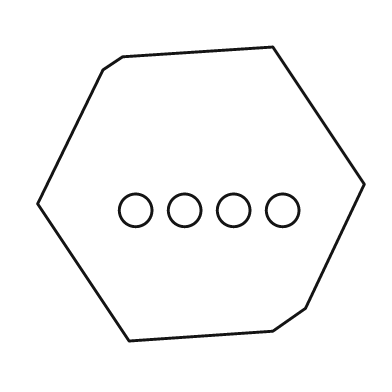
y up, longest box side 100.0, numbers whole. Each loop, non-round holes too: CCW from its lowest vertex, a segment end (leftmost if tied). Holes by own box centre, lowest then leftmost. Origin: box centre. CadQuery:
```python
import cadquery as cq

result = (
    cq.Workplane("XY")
    .moveTo(-22.0, -45.0)
    .lineTo(22.0, -42.0)
    .lineTo(32.0, -35.0)
    .lineTo(50.0, 3.0)
    .lineTo(22.0, 45.0)
    .lineTo(-24.0, 42.0)
    .lineTo(-30.0, 38.0)
    .lineTo(-50.0, -3.0)
    .close()
    .moveTo(-20.0, -5.0)
    .circle(5.0)
    .moveTo(-5.0, -5.0)
    .circle(5.0)
    .moveTo(10.0, -5.0)
    .circle(5.0)
    .moveTo(25.0, -5.0)
    .circle(5.0)
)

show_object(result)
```